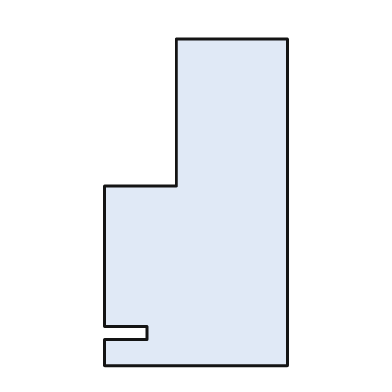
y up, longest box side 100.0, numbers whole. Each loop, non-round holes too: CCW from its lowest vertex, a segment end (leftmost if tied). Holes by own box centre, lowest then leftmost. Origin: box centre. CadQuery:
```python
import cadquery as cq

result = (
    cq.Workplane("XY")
    .moveTo(-28.0, -50.0)
    .lineTo(28.0, -50.0)
    .lineTo(28.0, 50.0)
    .lineTo(-6.0, 50.0)
    .lineTo(-6.0, 5.0)
    .lineTo(-28.0, 5.0)
    .lineTo(-28.0, -38.0)
    .lineTo(-15.0, -38.0)
    .lineTo(-15.0, -42.0)
    .lineTo(-28.0, -42.0)
    .close()
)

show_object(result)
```